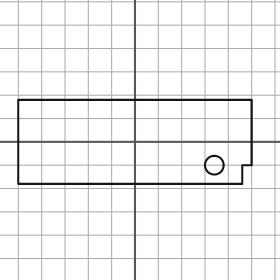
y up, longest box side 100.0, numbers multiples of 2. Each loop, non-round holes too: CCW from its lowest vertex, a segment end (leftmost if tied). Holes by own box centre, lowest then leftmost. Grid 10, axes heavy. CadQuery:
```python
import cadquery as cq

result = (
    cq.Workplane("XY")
    .moveTo(-50.0, -18.0)
    .lineTo(46.0, -18.0)
    .lineTo(46.0, -10.0)
    .lineTo(50.0, -10.0)
    .lineTo(50.0, 18.0)
    .lineTo(-50.0, 18.0)
    .close()
    .moveTo(34.0, -10.0)
    .circle(4.0)
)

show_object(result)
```